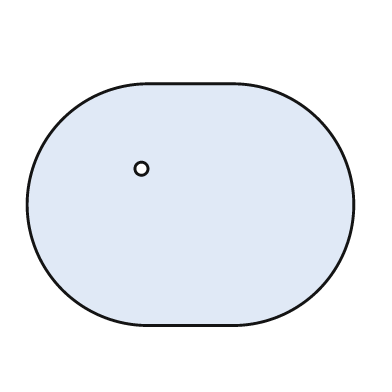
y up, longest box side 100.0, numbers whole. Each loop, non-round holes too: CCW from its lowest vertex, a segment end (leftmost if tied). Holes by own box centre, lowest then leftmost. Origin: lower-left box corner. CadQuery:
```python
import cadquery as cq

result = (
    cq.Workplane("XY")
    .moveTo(37.0, 0.0)
    .lineTo(63.0, 0.0)
    .threePointArc((100.0, 37.0), (63.0, 74.0))
    .lineTo(37.0, 74.0)
    .threePointArc((0.0, 37.0), (37.0, 0.0))
    .close()
    .moveTo(35.0, 48.0)
    .circle(2.0)
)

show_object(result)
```